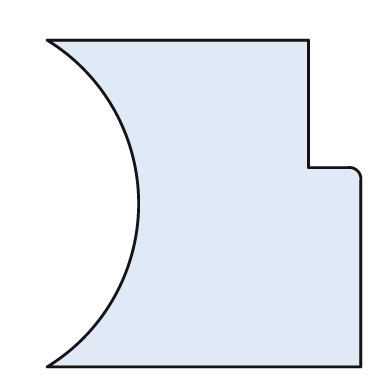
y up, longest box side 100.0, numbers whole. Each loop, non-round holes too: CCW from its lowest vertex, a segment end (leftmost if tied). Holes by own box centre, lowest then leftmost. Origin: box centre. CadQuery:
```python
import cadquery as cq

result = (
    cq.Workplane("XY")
    .moveTo(-48.0, -50.0)
    .lineTo(48.0, -50.0)
    .lineTo(48.0, 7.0)
    .threePointArc((47.0, 10.0), (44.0, 11.0))
    .lineTo(32.0, 11.0)
    .lineTo(32.0, 50.0)
    .lineTo(-48.0, 50.0)
    .threePointArc((-20.0, 0.0), (-48.0, -50.0))
    .close()
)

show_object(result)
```